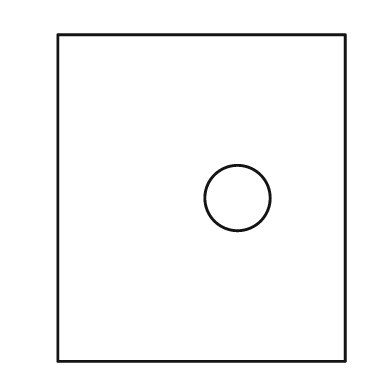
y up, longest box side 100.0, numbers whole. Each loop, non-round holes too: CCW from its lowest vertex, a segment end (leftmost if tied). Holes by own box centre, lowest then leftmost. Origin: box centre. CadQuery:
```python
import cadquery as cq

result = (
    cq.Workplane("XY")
    .moveTo(-44.0, -50.0)
    .lineTo(44.0, -50.0)
    .lineTo(44.0, 50.0)
    .lineTo(-44.0, 50.0)
    .close()
    .moveTo(11.0, 0.0)
    .circle(10.0)
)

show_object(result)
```